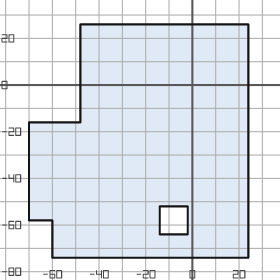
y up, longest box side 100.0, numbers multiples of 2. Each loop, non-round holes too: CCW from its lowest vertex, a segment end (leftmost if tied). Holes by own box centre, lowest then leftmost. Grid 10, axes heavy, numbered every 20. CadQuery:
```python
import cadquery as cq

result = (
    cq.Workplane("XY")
    .moveTo(-60.0, -74.0)
    .lineTo(24.0, -74.0)
    .lineTo(24.0, 26.0)
    .lineTo(-48.0, 26.0)
    .lineTo(-48.0, -16.0)
    .lineTo(-70.0, -16.0)
    .lineTo(-70.0, -58.0)
    .lineTo(-60.0, -58.0)
    .close()
    .moveTo(-14.0, -64.0)
    .lineTo(-2.0, -64.0)
    .lineTo(-2.0, -52.0)
    .lineTo(-14.0, -52.0)
    .close()
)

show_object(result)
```